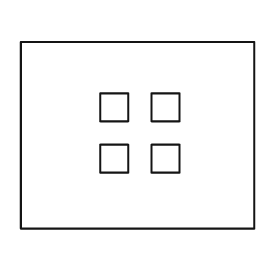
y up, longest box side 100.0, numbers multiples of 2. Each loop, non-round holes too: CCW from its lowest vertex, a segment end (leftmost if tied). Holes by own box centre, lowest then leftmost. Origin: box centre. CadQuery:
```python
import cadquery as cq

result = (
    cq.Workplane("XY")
    .moveTo(-50.0, -40.0)
    .lineTo(50.0, -40.0)
    .lineTo(50.0, 40.0)
    .lineTo(-50.0, 40.0)
    .close()
    .moveTo(-16.0, -16.0)
    .lineTo(-4.0, -16.0)
    .lineTo(-4.0, -4.0)
    .lineTo(-16.0, -4.0)
    .close()
    .moveTo(6.0, -16.0)
    .lineTo(18.0, -16.0)
    .lineTo(18.0, -4.0)
    .lineTo(6.0, -4.0)
    .close()
    .moveTo(-16.0, 6.0)
    .lineTo(-4.0, 6.0)
    .lineTo(-4.0, 18.0)
    .lineTo(-16.0, 18.0)
    .close()
    .moveTo(6.0, 6.0)
    .lineTo(18.0, 6.0)
    .lineTo(18.0, 18.0)
    .lineTo(6.0, 18.0)
    .close()
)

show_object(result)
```